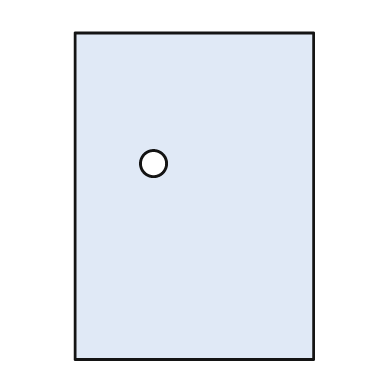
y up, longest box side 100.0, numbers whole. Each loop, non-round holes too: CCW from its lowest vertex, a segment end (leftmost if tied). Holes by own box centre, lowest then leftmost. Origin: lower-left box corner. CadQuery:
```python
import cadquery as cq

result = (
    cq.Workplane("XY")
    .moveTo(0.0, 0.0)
    .lineTo(73.0, 0.0)
    .lineTo(73.0, 100.0)
    .lineTo(0.0, 100.0)
    .close()
    .moveTo(24.0, 60.0)
    .circle(4.0)
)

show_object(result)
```